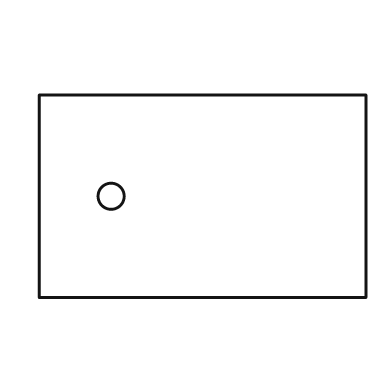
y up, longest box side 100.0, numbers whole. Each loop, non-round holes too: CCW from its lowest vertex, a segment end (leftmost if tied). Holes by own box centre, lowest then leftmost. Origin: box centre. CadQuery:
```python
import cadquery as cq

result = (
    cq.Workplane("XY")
    .moveTo(-50.0, -31.0)
    .lineTo(50.0, -31.0)
    .lineTo(50.0, 31.0)
    .lineTo(-50.0, 31.0)
    .close()
    .moveTo(-28.0, 0.0)
    .circle(4.0)
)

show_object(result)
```